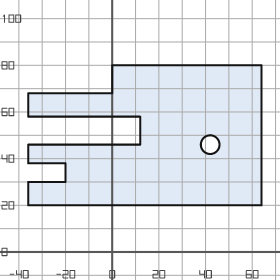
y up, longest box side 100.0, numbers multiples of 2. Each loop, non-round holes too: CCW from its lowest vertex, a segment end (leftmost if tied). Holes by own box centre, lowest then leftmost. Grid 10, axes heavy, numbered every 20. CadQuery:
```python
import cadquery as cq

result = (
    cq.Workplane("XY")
    .moveTo(-36.0, 20.0)
    .lineTo(64.0, 20.0)
    .lineTo(64.0, 80.0)
    .lineTo(0.0, 80.0)
    .lineTo(0.0, 68.0)
    .lineTo(-36.0, 68.0)
    .lineTo(-36.0, 58.0)
    .lineTo(12.0, 58.0)
    .lineTo(12.0, 46.0)
    .lineTo(-36.0, 46.0)
    .lineTo(-36.0, 38.0)
    .lineTo(-20.0, 38.0)
    .lineTo(-20.0, 30.0)
    .lineTo(-36.0, 30.0)
    .close()
    .moveTo(42.0, 46.0)
    .circle(4.0)
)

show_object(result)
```